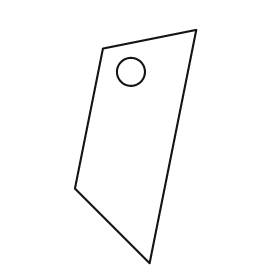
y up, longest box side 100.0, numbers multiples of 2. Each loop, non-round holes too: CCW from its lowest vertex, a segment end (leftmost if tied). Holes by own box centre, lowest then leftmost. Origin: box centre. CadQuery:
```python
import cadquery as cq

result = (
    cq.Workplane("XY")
    .moveTo(6.0, -50.0)
    .lineTo(26.0, 50.0)
    .lineTo(-14.0, 42.0)
    .lineTo(-26.0, -18.0)
    .close()
    .moveTo(-2.0, 32.0)
    .circle(6.0)
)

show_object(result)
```